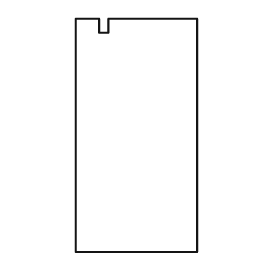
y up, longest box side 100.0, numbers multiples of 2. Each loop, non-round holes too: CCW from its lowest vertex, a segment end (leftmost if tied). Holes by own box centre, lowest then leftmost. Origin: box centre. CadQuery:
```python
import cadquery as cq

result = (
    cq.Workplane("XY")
    .moveTo(-26.0, -50.0)
    .lineTo(26.0, -50.0)
    .lineTo(26.0, 50.0)
    .lineTo(-12.0, 50.0)
    .lineTo(-12.0, 44.0)
    .lineTo(-16.0, 44.0)
    .lineTo(-16.0, 50.0)
    .lineTo(-26.0, 50.0)
    .close()
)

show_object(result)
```